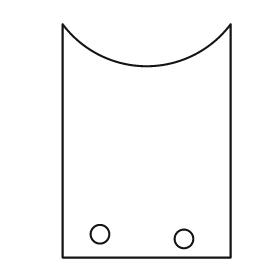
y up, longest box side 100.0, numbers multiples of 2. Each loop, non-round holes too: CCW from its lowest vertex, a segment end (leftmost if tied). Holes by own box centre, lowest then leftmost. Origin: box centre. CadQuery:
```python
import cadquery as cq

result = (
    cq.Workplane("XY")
    .moveTo(-36.0, -50.0)
    .lineTo(36.0, -50.0)
    .lineTo(36.0, 50.0)
    .threePointArc((0.0, 32.0), (-36.0, 50.0))
    .close()
    .moveTo(16.0, -42.0)
    .circle(4.0)
    .moveTo(-20.0, -40.0)
    .circle(4.0)
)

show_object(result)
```